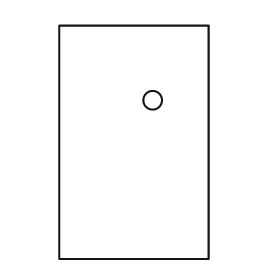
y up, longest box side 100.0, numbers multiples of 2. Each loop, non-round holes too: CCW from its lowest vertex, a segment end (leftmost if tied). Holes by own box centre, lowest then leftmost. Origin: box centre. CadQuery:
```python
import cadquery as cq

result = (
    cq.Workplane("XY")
    .moveTo(-32.0, -50.0)
    .lineTo(32.0, -50.0)
    .lineTo(32.0, 50.0)
    .lineTo(-32.0, 50.0)
    .close()
    .moveTo(8.0, 18.0)
    .circle(4.0)
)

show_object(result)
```